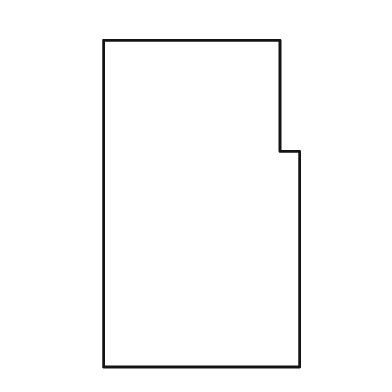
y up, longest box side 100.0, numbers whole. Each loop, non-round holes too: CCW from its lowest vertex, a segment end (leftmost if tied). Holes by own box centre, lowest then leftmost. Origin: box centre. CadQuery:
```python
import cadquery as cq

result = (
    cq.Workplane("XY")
    .moveTo(-30.0, -50.0)
    .lineTo(30.0, -50.0)
    .lineTo(30.0, 16.0)
    .lineTo(24.0, 16.0)
    .lineTo(24.0, 50.0)
    .lineTo(-30.0, 50.0)
    .close()
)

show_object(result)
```